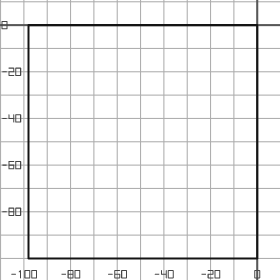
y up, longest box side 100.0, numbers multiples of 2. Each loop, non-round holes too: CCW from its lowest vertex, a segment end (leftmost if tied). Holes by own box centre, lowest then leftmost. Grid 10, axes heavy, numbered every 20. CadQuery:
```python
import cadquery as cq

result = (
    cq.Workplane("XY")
    .moveTo(-98.0, -100.0)
    .lineTo(0.0, -100.0)
    .lineTo(0.0, 0.0)
    .lineTo(-98.0, 0.0)
    .close()
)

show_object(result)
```